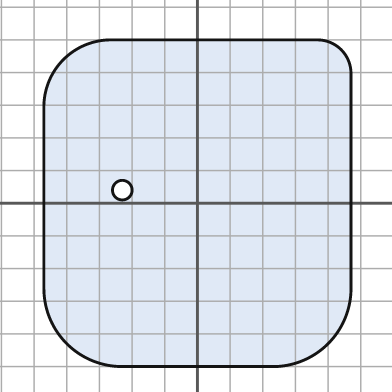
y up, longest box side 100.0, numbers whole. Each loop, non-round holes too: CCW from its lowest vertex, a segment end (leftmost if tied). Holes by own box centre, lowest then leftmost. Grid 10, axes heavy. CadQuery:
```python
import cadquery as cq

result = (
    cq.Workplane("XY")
    .moveTo(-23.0, -50.0)
    .lineTo(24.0, -50.0)
    .threePointArc((40.0, -43.0), (47.0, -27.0))
    .lineTo(47.0, 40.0)
    .threePointArc((44.0, 47.0), (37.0, 50.0))
    .lineTo(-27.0, 50.0)
    .threePointArc((-41.0, 44.0), (-47.0, 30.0))
    .lineTo(-47.0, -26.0)
    .threePointArc((-40.0, -43.0), (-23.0, -50.0))
    .close()
    .moveTo(-23.0, 4.0)
    .circle(3.0)
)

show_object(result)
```